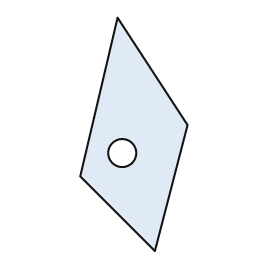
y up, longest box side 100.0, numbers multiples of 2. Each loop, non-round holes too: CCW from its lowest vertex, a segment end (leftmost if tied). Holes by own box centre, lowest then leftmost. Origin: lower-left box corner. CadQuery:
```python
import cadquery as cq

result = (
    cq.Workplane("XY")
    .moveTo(32.0, 0.0)
    .lineTo(46.0, 54.0)
    .lineTo(16.0, 100.0)
    .lineTo(0.0, 32.0)
    .close()
    .moveTo(18.0, 42.0)
    .circle(6.0)
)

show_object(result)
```